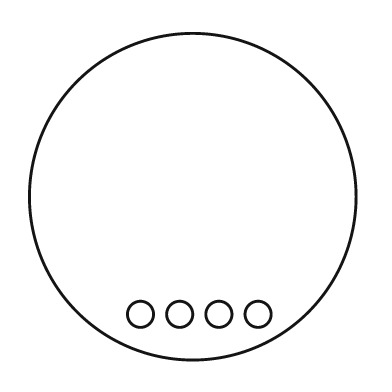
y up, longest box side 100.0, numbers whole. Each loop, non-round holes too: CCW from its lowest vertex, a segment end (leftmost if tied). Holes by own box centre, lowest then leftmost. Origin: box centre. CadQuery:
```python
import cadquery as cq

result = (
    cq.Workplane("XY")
    .moveTo(0.0, 0.0)
    .circle(50.0)
    .moveTo(-16.0, -36.0)
    .circle(4.0)
    .moveTo(-4.0, -36.0)
    .circle(4.0)
    .moveTo(8.0, -36.0)
    .circle(4.0)
    .moveTo(20.0, -36.0)
    .circle(4.0)
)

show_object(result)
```